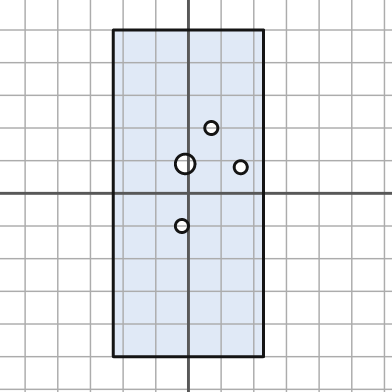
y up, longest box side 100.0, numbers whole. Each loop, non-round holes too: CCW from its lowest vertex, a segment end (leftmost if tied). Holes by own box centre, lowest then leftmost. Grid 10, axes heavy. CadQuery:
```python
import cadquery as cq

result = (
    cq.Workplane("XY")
    .moveTo(-23.0, -50.0)
    .lineTo(23.0, -50.0)
    .lineTo(23.0, 50.0)
    .lineTo(-23.0, 50.0)
    .close()
    .moveTo(-2.0, -10.0)
    .circle(2.0)
    .moveTo(16.0, 8.0)
    .circle(2.0)
    .moveTo(-1.0, 9.0)
    .circle(3.0)
    .moveTo(7.0, 20.0)
    .circle(2.0)
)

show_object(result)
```